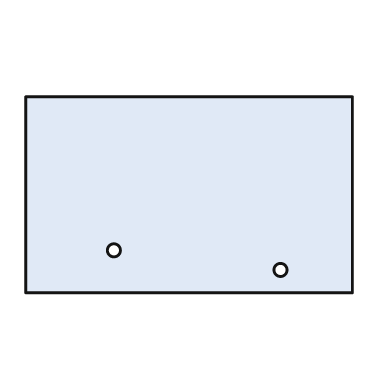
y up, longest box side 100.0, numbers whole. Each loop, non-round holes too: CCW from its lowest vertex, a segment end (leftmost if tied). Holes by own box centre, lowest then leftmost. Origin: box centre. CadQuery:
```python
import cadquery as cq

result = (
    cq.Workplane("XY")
    .moveTo(-50.0, -30.0)
    .lineTo(50.0, -30.0)
    .lineTo(50.0, 30.0)
    .lineTo(-50.0, 30.0)
    .close()
    .moveTo(28.0, -23.0)
    .circle(2.0)
    .moveTo(-23.0, -17.0)
    .circle(2.0)
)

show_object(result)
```